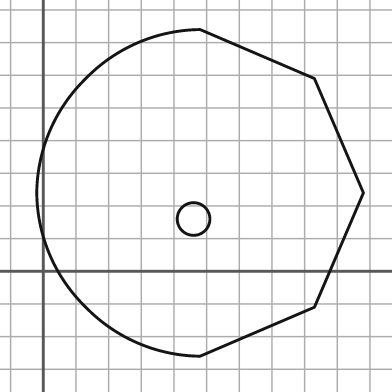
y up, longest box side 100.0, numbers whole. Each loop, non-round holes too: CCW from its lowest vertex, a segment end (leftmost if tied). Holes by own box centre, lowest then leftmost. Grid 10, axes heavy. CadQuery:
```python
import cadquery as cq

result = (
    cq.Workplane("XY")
    .moveTo(48.0, -26.0)
    .lineTo(83.0, -11.0)
    .lineTo(98.0, 24.0)
    .lineTo(83.0, 59.0)
    .lineTo(48.0, 74.0)
    .threePointArc((29.0, 70.0), (13.0, 59.0))
    .threePointArc((2.0, 43.0), (-2.0, 24.0))
    .threePointArc((2.0, 5.0), (13.0, -11.0))
    .threePointArc((29.0, -22.0), (48.0, -26.0))
    .close()
    .moveTo(46.0, 16.0)
    .circle(5.0)
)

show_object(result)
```